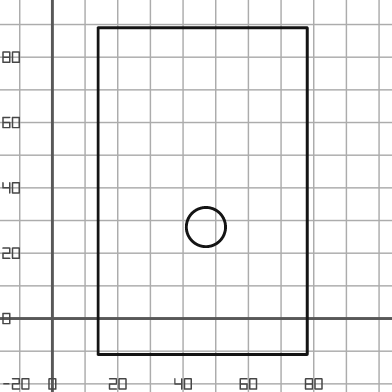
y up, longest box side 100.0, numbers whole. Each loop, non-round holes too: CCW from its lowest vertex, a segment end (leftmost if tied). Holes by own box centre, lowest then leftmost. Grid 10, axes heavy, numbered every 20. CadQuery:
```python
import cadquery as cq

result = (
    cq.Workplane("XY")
    .moveTo(14.0, -11.0)
    .lineTo(78.0, -11.0)
    .lineTo(78.0, 89.0)
    .lineTo(14.0, 89.0)
    .close()
    .moveTo(47.0, 28.0)
    .circle(6.0)
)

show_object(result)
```